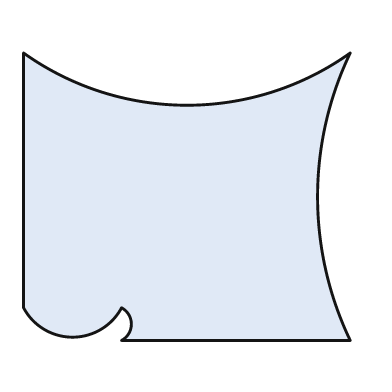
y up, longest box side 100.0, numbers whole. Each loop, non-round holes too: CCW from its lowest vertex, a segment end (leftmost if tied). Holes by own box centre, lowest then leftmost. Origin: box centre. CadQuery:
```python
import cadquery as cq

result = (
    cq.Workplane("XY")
    .moveTo(-20.0, -44.0)
    .lineTo(50.0, -44.0)
    .threePointArc((40.0, 0.0), (50.0, 44.0))
    .threePointArc((0.0, 28.0), (-50.0, 44.0))
    .lineTo(-50.0, -34.0)
    .threePointArc((-35.0, -43.0), (-20.0, -34.0))
    .threePointArc((-17.0, -39.0), (-20.0, -44.0))
    .close()
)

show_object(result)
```